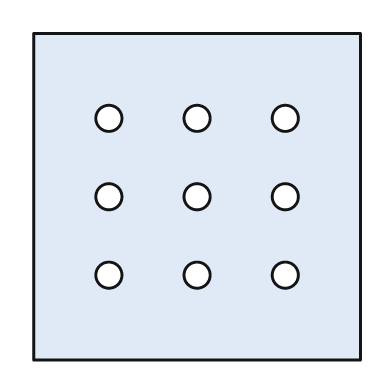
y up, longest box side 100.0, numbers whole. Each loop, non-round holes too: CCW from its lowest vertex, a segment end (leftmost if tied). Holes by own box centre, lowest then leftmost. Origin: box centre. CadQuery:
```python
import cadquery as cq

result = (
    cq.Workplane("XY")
    .moveTo(-50.0, -50.0)
    .lineTo(50.0, -50.0)
    .lineTo(50.0, 50.0)
    .lineTo(-50.0, 50.0)
    .close()
    .moveTo(-27.0, -24.0)
    .circle(4.0)
    .moveTo(0.0, -24.0)
    .circle(4.0)
    .moveTo(27.0, -24.0)
    .circle(4.0)
    .moveTo(-27.0, 0.0)
    .circle(4.0)
    .moveTo(0.0, 0.0)
    .circle(4.0)
    .moveTo(27.0, 0.0)
    .circle(4.0)
    .moveTo(-27.0, 24.0)
    .circle(4.0)
    .moveTo(0.0, 24.0)
    .circle(4.0)
    .moveTo(27.0, 24.0)
    .circle(4.0)
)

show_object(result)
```